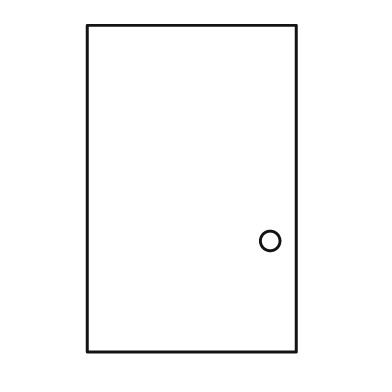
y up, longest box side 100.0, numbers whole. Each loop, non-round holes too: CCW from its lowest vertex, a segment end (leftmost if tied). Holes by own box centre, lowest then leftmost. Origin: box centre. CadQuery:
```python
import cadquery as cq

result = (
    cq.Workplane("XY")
    .moveTo(-32.0, -50.0)
    .lineTo(32.0, -50.0)
    .lineTo(32.0, 50.0)
    .lineTo(-32.0, 50.0)
    .close()
    .moveTo(24.0, -16.0)
    .circle(3.0)
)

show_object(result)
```